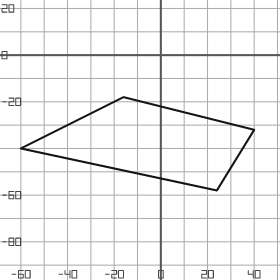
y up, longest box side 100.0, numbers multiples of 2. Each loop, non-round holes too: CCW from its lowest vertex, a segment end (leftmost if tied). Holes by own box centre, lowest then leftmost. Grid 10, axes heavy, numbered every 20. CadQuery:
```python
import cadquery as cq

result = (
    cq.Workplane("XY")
    .moveTo(24.0, -58.0)
    .lineTo(40.0, -32.0)
    .lineTo(-16.0, -18.0)
    .lineTo(-60.0, -40.0)
    .close()
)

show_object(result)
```